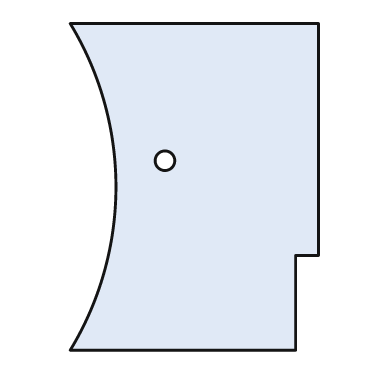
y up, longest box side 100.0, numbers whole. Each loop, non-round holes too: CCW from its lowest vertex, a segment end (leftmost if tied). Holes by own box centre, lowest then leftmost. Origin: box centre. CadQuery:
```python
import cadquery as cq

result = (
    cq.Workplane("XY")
    .moveTo(-38.0, -50.0)
    .lineTo(31.0, -50.0)
    .lineTo(31.0, -21.0)
    .lineTo(38.0, -21.0)
    .lineTo(38.0, 50.0)
    .lineTo(-38.0, 50.0)
    .threePointArc((-24.0, 0.0), (-38.0, -50.0))
    .close()
    .moveTo(-9.0, 8.0)
    .circle(3.0)
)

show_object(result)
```